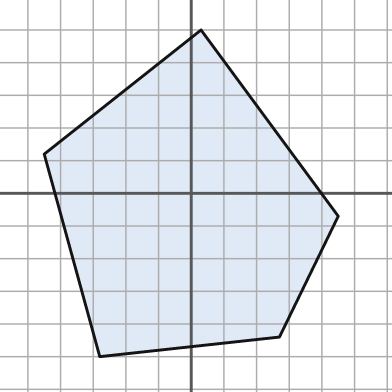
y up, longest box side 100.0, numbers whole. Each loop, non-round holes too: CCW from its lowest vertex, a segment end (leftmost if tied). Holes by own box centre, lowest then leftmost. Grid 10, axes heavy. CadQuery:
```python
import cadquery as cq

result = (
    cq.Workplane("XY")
    .moveTo(-28.0, -50.0)
    .lineTo(27.0, -44.0)
    .lineTo(45.0, -7.0)
    .lineTo(3.0, 50.0)
    .lineTo(-45.0, 12.0)
    .close()
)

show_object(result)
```